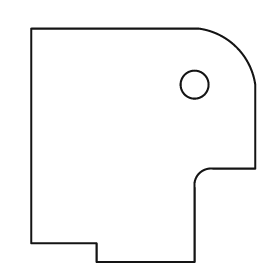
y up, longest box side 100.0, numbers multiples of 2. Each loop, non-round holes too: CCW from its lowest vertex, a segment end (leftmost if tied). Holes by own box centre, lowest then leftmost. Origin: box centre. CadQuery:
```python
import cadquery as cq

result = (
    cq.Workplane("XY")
    .moveTo(-20.0, -50.0)
    .lineTo(22.0, -50.0)
    .lineTo(22.0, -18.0)
    .threePointArc((24.0, -12.0), (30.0, -10.0))
    .lineTo(48.0, -10.0)
    .lineTo(48.0, 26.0)
    .threePointArc((40.0, 42.0), (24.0, 50.0))
    .lineTo(-48.0, 50.0)
    .lineTo(-48.0, -42.0)
    .lineTo(-20.0, -42.0)
    .close()
    .moveTo(22.0, 26.0)
    .circle(6.0)
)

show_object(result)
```